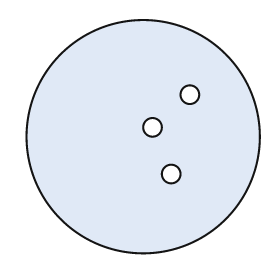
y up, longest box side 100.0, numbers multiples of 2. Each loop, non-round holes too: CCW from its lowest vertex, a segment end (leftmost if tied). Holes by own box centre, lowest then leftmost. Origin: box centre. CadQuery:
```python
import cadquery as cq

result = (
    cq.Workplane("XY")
    .moveTo(0.0, 0.0)
    .circle(50.0)
    .moveTo(12.0, -16.0)
    .circle(4.0)
    .moveTo(4.0, 4.0)
    .circle(4.0)
    .moveTo(20.0, 18.0)
    .circle(4.0)
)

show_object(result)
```